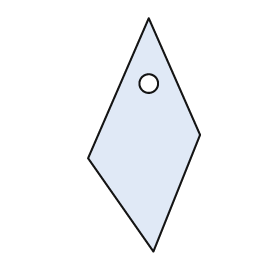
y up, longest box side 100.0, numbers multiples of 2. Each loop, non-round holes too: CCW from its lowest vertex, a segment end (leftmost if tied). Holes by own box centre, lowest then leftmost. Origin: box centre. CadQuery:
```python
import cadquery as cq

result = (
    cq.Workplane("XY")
    .moveTo(4.0, -50.0)
    .lineTo(24.0, 0.0)
    .lineTo(2.0, 50.0)
    .lineTo(-24.0, -10.0)
    .close()
    .moveTo(2.0, 22.0)
    .circle(4.0)
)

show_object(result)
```